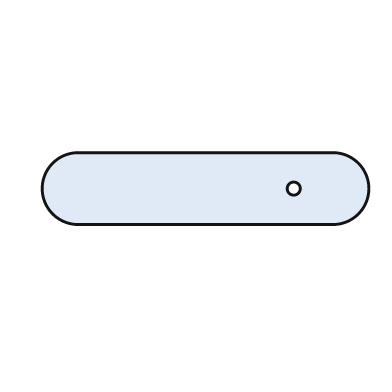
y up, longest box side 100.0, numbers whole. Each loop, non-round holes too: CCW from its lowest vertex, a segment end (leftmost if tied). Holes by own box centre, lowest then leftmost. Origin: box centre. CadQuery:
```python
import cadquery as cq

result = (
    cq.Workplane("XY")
    .moveTo(-39.0, -11.0)
    .lineTo(39.0, -11.0)
    .threePointArc((50.0, 0.0), (39.0, 11.0))
    .lineTo(-39.0, 11.0)
    .threePointArc((-50.0, 0.0), (-39.0, -11.0))
    .close()
    .moveTo(27.0, 0.0)
    .circle(2.0)
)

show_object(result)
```